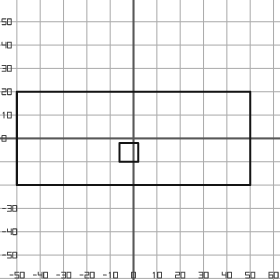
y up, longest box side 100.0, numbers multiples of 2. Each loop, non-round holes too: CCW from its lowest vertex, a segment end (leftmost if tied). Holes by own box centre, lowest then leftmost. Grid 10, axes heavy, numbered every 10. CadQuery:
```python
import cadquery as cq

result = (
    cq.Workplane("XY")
    .moveTo(-50.0, -20.0)
    .lineTo(50.0, -20.0)
    .lineTo(50.0, 20.0)
    .lineTo(-50.0, 20.0)
    .close()
    .moveTo(-6.0, -10.0)
    .lineTo(2.0, -10.0)
    .lineTo(2.0, -2.0)
    .lineTo(-6.0, -2.0)
    .close()
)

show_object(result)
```